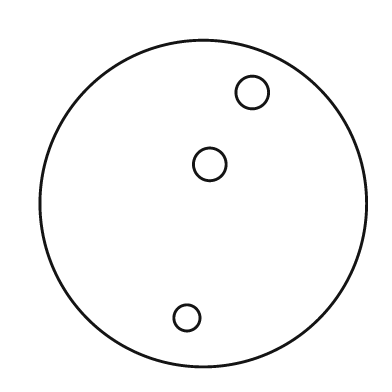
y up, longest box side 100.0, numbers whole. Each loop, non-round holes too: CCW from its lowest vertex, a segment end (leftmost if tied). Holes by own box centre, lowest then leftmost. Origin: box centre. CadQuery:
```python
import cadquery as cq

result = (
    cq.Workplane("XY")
    .moveTo(0.0, 0.0)
    .circle(50.0)
    .moveTo(-5.0, -35.0)
    .circle(4.0)
    .moveTo(2.0, 12.0)
    .circle(5.0)
    .moveTo(15.0, 34.0)
    .circle(5.0)
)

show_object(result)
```